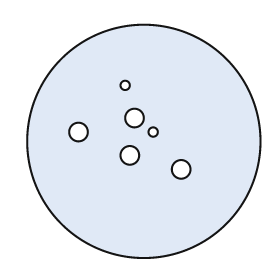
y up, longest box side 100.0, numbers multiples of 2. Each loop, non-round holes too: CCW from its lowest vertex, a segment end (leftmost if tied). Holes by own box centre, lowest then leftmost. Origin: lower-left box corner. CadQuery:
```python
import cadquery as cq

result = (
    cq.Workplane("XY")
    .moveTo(50.0, 50.0)
    .circle(50.0)
    .moveTo(66.0, 38.0)
    .circle(4.0)
    .moveTo(44.0, 44.0)
    .circle(4.0)
    .moveTo(22.0, 54.0)
    .circle(4.0)
    .moveTo(54.0, 54.0)
    .circle(2.0)
    .moveTo(46.0, 60.0)
    .circle(4.0)
    .moveTo(42.0, 74.0)
    .circle(2.0)
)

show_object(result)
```